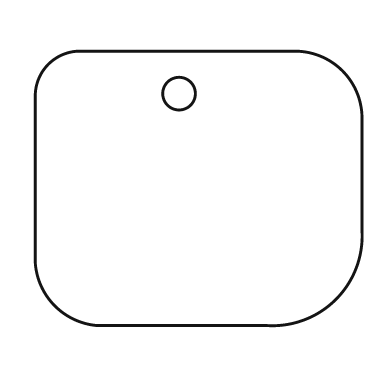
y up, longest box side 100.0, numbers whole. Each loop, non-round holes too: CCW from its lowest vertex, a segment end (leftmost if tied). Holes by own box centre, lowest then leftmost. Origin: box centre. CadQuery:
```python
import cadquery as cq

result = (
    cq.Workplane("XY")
    .moveTo(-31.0, -42.0)
    .lineTo(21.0, -42.0)
    .threePointArc((42.0, -34.0), (50.0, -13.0))
    .lineTo(50.0, 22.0)
    .threePointArc((44.0, 36.0), (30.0, 42.0))
    .lineTo(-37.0, 42.0)
    .threePointArc((-46.0, 38.0), (-50.0, 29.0))
    .lineTo(-50.0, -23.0)
    .threePointArc((-44.0, -36.0), (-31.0, -42.0))
    .close()
    .moveTo(-6.0, 29.0)
    .circle(5.0)
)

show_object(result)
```